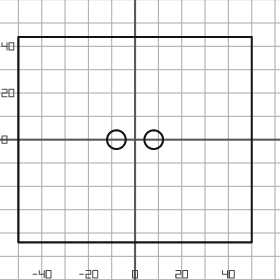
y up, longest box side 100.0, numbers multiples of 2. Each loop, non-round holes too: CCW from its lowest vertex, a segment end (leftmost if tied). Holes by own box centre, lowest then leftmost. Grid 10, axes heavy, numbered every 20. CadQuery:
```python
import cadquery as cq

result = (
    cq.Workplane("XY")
    .moveTo(-50.0, -44.0)
    .lineTo(50.0, -44.0)
    .lineTo(50.0, 44.0)
    .lineTo(-50.0, 44.0)
    .close()
    .moveTo(-8.0, 0.0)
    .circle(4.0)
    .moveTo(8.0, 0.0)
    .circle(4.0)
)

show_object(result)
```